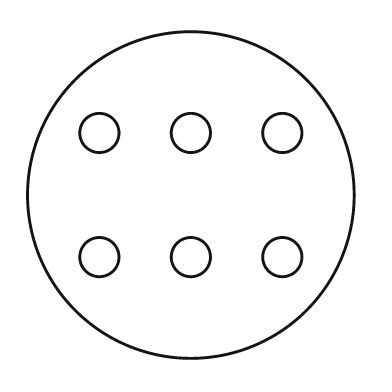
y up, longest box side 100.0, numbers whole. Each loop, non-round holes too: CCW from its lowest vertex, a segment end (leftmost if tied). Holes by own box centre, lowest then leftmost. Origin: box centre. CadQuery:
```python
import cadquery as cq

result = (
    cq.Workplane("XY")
    .moveTo(0.0, 0.0)
    .circle(50.0)
    .moveTo(-28.0, -19.0)
    .circle(6.0)
    .moveTo(0.0, -19.0)
    .circle(6.0)
    .moveTo(28.0, -19.0)
    .circle(6.0)
    .moveTo(-28.0, 19.0)
    .circle(6.0)
    .moveTo(0.0, 19.0)
    .circle(6.0)
    .moveTo(28.0, 19.0)
    .circle(6.0)
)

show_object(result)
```